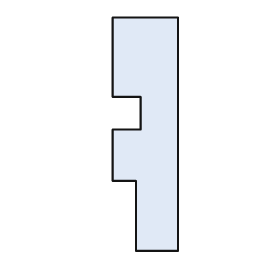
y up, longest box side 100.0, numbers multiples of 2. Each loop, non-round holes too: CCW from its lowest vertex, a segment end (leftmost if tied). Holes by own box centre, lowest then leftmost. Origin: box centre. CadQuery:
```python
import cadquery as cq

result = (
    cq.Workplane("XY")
    .moveTo(-4.0, -50.0)
    .lineTo(14.0, -50.0)
    .lineTo(14.0, 50.0)
    .lineTo(-14.0, 50.0)
    .lineTo(-14.0, 16.0)
    .lineTo(-2.0, 16.0)
    .lineTo(-2.0, 2.0)
    .lineTo(-14.0, 2.0)
    .lineTo(-14.0, -20.0)
    .lineTo(-4.0, -20.0)
    .close()
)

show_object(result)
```